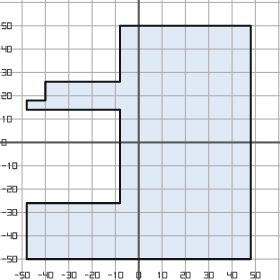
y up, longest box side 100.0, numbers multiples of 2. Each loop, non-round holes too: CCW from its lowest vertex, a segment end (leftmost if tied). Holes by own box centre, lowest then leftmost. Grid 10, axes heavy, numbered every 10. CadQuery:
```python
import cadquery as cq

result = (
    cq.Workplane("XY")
    .moveTo(-48.0, -50.0)
    .lineTo(48.0, -50.0)
    .lineTo(48.0, 50.0)
    .lineTo(-8.0, 50.0)
    .lineTo(-8.0, 26.0)
    .lineTo(-40.0, 26.0)
    .lineTo(-40.0, 18.0)
    .lineTo(-48.0, 18.0)
    .lineTo(-48.0, 14.0)
    .lineTo(-8.0, 14.0)
    .lineTo(-8.0, -26.0)
    .lineTo(-48.0, -26.0)
    .close()
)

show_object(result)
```